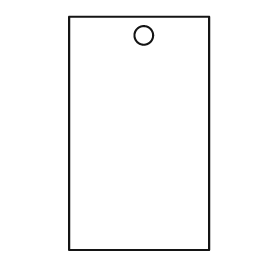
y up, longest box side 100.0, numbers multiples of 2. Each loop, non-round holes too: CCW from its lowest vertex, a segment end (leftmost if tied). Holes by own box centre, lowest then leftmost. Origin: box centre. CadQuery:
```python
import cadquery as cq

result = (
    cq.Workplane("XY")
    .moveTo(-30.0, -50.0)
    .lineTo(30.0, -50.0)
    .lineTo(30.0, 50.0)
    .lineTo(-30.0, 50.0)
    .close()
    .moveTo(2.0, 42.0)
    .circle(4.0)
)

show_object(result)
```